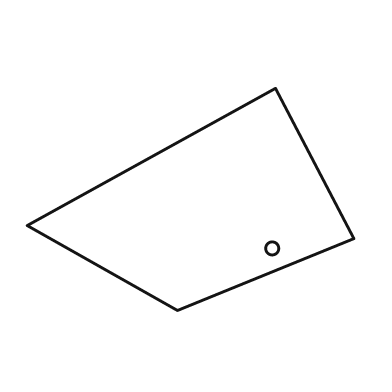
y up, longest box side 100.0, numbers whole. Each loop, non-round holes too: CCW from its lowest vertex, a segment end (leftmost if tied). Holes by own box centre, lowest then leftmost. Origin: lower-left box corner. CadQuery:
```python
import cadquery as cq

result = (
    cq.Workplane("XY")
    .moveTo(46.0, 0.0)
    .lineTo(100.0, 22.0)
    .lineTo(76.0, 68.0)
    .lineTo(0.0, 26.0)
    .close()
    .moveTo(75.0, 19.0)
    .circle(2.0)
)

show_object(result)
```